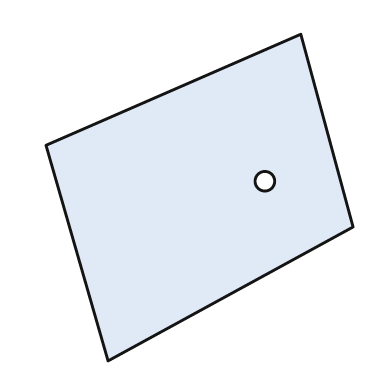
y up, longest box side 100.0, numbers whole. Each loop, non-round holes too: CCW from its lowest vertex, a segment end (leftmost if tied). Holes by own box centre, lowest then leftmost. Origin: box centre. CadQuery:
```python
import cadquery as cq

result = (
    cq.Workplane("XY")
    .moveTo(-28.0, -50.0)
    .lineTo(47.0, -9.0)
    .lineTo(31.0, 50.0)
    .lineTo(-47.0, 16.0)
    .close()
    .moveTo(20.0, 5.0)
    .circle(3.0)
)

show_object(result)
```